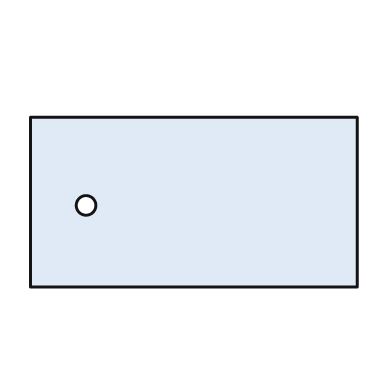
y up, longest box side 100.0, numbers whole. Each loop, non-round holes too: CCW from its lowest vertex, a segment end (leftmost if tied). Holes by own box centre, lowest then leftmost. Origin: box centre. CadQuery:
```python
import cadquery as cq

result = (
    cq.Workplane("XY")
    .moveTo(-50.0, -26.0)
    .lineTo(50.0, -26.0)
    .lineTo(50.0, 26.0)
    .lineTo(-50.0, 26.0)
    .close()
    .moveTo(-33.0, -1.0)
    .circle(3.0)
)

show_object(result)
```